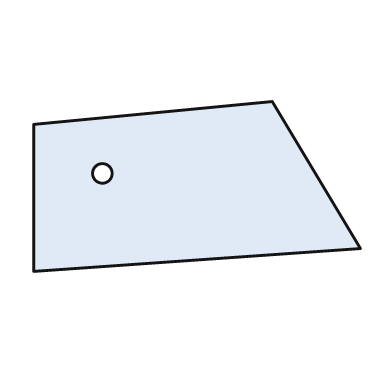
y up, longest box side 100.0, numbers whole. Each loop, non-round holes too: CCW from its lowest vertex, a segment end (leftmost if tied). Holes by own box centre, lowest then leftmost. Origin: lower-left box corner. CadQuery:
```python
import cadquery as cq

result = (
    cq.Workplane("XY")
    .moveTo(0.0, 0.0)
    .lineTo(100.0, 7.0)
    .lineTo(73.0, 52.0)
    .lineTo(0.0, 45.0)
    .close()
    .moveTo(21.0, 30.0)
    .circle(3.0)
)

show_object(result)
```